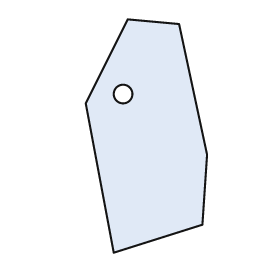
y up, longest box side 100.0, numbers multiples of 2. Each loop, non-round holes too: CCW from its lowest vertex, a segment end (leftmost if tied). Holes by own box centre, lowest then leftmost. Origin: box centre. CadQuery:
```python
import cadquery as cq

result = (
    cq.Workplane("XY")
    .moveTo(-14.0, -50.0)
    .lineTo(24.0, -38.0)
    .lineTo(26.0, -8.0)
    .lineTo(14.0, 48.0)
    .lineTo(-8.0, 50.0)
    .lineTo(-26.0, 14.0)
    .close()
    .moveTo(-10.0, 18.0)
    .circle(4.0)
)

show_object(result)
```